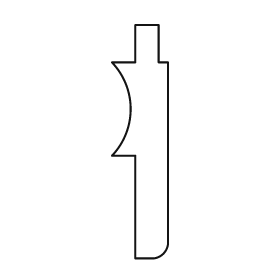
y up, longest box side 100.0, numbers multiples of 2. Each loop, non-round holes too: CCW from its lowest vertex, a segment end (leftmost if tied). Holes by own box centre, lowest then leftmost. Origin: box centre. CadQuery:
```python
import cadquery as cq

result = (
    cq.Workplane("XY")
    .moveTo(-2.0, -50.0)
    .lineTo(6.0, -50.0)
    .threePointArc((10.0, -48.0), (12.0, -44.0))
    .lineTo(12.0, 34.0)
    .lineTo(8.0, 34.0)
    .lineTo(8.0, 50.0)
    .lineTo(-2.0, 50.0)
    .lineTo(-2.0, 34.0)
    .lineTo(-12.0, 34.0)
    .threePointArc((-4.0, 14.0), (-12.0, -6.0))
    .lineTo(-2.0, -6.0)
    .close()
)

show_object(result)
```